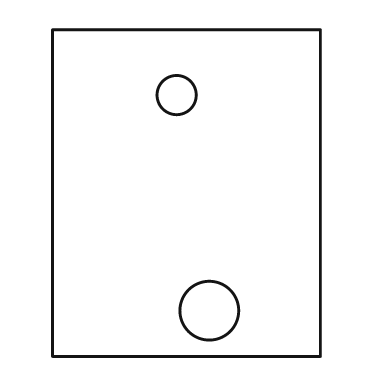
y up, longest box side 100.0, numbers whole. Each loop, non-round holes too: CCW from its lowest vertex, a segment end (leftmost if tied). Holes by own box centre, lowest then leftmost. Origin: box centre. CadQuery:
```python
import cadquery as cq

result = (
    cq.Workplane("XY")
    .moveTo(-41.0, -50.0)
    .lineTo(41.0, -50.0)
    .lineTo(41.0, 50.0)
    .lineTo(-41.0, 50.0)
    .close()
    .moveTo(7.0, -36.0)
    .circle(9.0)
    .moveTo(-3.0, 30.0)
    .circle(6.0)
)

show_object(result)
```